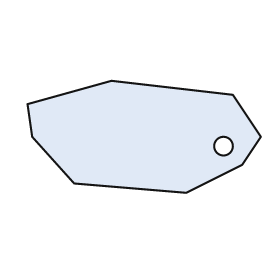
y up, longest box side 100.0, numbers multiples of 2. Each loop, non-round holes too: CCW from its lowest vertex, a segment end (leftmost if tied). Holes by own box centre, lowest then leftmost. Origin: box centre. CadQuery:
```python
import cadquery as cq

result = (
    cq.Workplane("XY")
    .moveTo(18.0, -24.0)
    .lineTo(42.0, -12.0)
    .lineTo(50.0, 0.0)
    .lineTo(38.0, 18.0)
    .lineTo(-14.0, 24.0)
    .lineTo(-50.0, 14.0)
    .lineTo(-48.0, 0.0)
    .lineTo(-30.0, -20.0)
    .close()
    .moveTo(34.0, -4.0)
    .circle(4.0)
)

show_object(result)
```